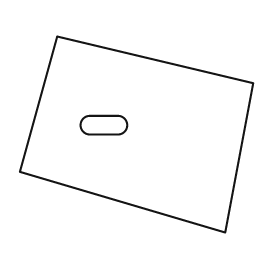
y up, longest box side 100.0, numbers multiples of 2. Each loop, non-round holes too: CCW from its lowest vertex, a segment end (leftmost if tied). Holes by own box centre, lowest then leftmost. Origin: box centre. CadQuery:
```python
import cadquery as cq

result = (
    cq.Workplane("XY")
    .moveTo(38.0, -42.0)
    .lineTo(50.0, 22.0)
    .lineTo(-34.0, 42.0)
    .lineTo(-50.0, -16.0)
    .close()
    .moveTo(-20.0, 0.0)
    .lineTo(-8.0, 0.0)
    .threePointArc((-4.0, 4.0), (-8.0, 8.0))
    .lineTo(-20.0, 8.0)
    .threePointArc((-24.0, 4.0), (-20.0, 0.0))
    .close()
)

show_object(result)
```